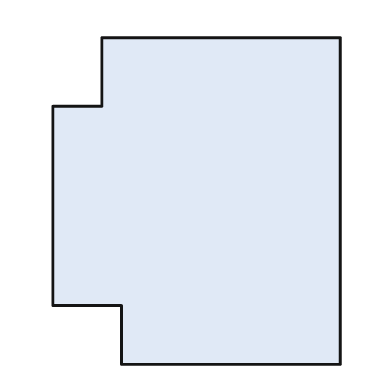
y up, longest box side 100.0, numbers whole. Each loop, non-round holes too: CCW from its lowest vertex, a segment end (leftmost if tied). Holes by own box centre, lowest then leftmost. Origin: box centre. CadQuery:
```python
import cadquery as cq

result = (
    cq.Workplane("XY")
    .moveTo(-23.0, -50.0)
    .lineTo(44.0, -50.0)
    .lineTo(44.0, 50.0)
    .lineTo(-29.0, 50.0)
    .lineTo(-29.0, 29.0)
    .lineTo(-44.0, 29.0)
    .lineTo(-44.0, -32.0)
    .lineTo(-23.0, -32.0)
    .close()
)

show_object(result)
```